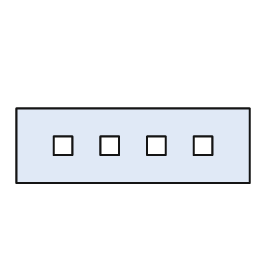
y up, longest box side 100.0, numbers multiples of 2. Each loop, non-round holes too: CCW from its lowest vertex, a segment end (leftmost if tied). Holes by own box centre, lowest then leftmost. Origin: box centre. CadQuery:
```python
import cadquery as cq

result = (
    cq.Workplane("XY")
    .moveTo(-50.0, -16.0)
    .lineTo(50.0, -16.0)
    .lineTo(50.0, 16.0)
    .lineTo(-50.0, 16.0)
    .close()
    .moveTo(-34.0, -4.0)
    .lineTo(-26.0, -4.0)
    .lineTo(-26.0, 4.0)
    .lineTo(-34.0, 4.0)
    .close()
    .moveTo(-14.0, -4.0)
    .lineTo(-6.0, -4.0)
    .lineTo(-6.0, 4.0)
    .lineTo(-14.0, 4.0)
    .close()
    .moveTo(6.0, -4.0)
    .lineTo(14.0, -4.0)
    .lineTo(14.0, 4.0)
    .lineTo(6.0, 4.0)
    .close()
    .moveTo(26.0, -4.0)
    .lineTo(34.0, -4.0)
    .lineTo(34.0, 4.0)
    .lineTo(26.0, 4.0)
    .close()
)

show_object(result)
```